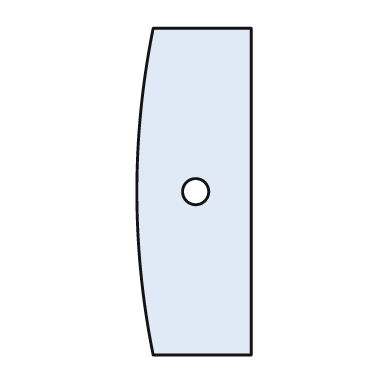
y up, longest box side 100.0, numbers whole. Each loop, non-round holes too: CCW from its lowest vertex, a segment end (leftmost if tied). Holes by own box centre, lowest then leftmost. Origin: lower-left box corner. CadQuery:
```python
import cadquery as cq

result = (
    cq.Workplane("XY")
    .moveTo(5.0, 0.0)
    .lineTo(35.0, 0.0)
    .lineTo(35.0, 100.0)
    .lineTo(5.0, 100.0)
    .threePointArc((0.0, 50.0), (5.0, 0.0))
    .close()
    .moveTo(18.0, 50.0)
    .circle(4.0)
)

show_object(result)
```